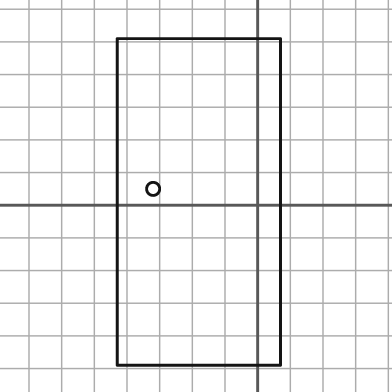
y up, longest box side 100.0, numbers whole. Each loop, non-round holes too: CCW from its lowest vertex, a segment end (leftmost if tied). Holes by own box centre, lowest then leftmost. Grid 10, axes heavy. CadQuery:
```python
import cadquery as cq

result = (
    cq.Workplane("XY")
    .moveTo(-43.0, -49.0)
    .lineTo(7.0, -49.0)
    .lineTo(7.0, 51.0)
    .lineTo(-43.0, 51.0)
    .close()
    .moveTo(-32.0, 5.0)
    .circle(2.0)
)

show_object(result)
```